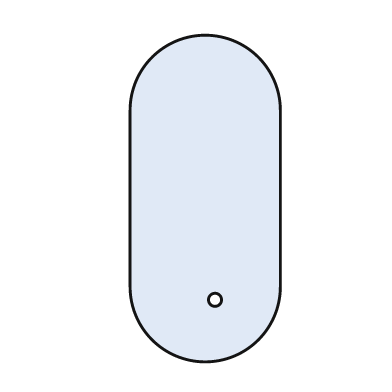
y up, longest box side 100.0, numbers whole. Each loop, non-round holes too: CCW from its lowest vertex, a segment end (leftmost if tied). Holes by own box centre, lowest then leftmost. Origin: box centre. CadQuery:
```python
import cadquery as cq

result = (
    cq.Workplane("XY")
    .moveTo(-23.0, -27.0)
    .threePointArc((0.0, -50.0), (23.0, -27.0))
    .lineTo(23.0, 27.0)
    .threePointArc((0.0, 50.0), (-23.0, 27.0))
    .close()
    .moveTo(3.0, -31.0)
    .circle(2.0)
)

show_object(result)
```